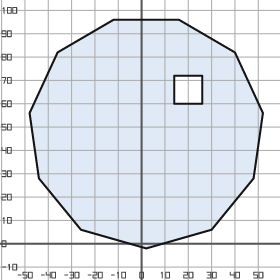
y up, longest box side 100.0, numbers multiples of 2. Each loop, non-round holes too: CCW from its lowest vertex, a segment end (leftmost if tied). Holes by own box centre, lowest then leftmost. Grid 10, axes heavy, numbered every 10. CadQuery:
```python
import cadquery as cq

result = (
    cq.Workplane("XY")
    .moveTo(2.0, -2.0)
    .lineTo(30.0, 6.0)
    .lineTo(48.0, 28.0)
    .lineTo(52.0, 56.0)
    .lineTo(40.0, 82.0)
    .lineTo(16.0, 96.0)
    .lineTo(-12.0, 96.0)
    .lineTo(-36.0, 82.0)
    .lineTo(-48.0, 56.0)
    .lineTo(-44.0, 28.0)
    .lineTo(-26.0, 6.0)
    .close()
    .moveTo(14.0, 60.0)
    .lineTo(26.0, 60.0)
    .lineTo(26.0, 72.0)
    .lineTo(14.0, 72.0)
    .close()
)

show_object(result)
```